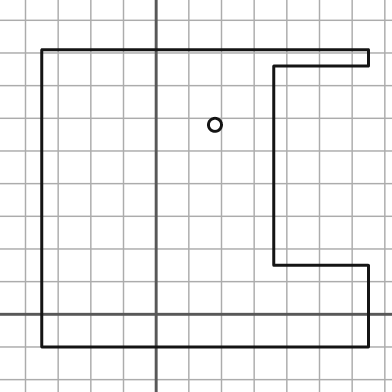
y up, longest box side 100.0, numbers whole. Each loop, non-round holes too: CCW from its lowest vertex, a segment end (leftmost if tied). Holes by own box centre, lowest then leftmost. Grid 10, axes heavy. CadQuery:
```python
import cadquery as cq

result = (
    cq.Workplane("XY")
    .moveTo(-35.0, -10.0)
    .lineTo(65.0, -10.0)
    .lineTo(65.0, 15.0)
    .lineTo(36.0, 15.0)
    .lineTo(36.0, 76.0)
    .lineTo(65.0, 76.0)
    .lineTo(65.0, 81.0)
    .lineTo(-35.0, 81.0)
    .close()
    .moveTo(18.0, 58.0)
    .circle(2.0)
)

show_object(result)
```